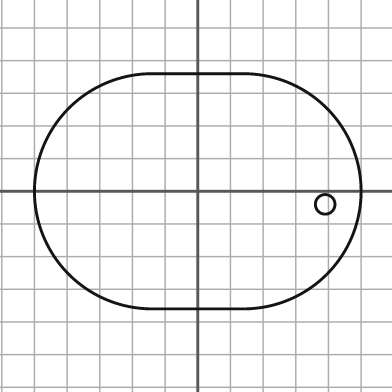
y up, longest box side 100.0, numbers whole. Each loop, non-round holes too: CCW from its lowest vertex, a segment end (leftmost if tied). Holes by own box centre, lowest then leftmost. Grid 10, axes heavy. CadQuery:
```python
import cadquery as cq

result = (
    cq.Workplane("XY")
    .moveTo(-14.0, -36.0)
    .lineTo(14.0, -36.0)
    .threePointArc((50.0, 0.0), (14.0, 36.0))
    .lineTo(-14.0, 36.0)
    .threePointArc((-50.0, 0.0), (-14.0, -36.0))
    .close()
    .moveTo(39.0, -4.0)
    .circle(3.0)
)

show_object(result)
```